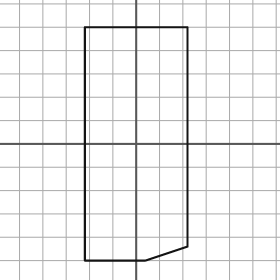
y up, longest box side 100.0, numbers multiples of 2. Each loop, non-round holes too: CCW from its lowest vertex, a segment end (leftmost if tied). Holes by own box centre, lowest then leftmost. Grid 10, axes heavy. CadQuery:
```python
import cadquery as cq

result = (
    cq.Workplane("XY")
    .moveTo(-22.0, -50.0)
    .lineTo(4.0, -50.0)
    .lineTo(22.0, -44.0)
    .lineTo(22.0, 50.0)
    .lineTo(-22.0, 50.0)
    .close()
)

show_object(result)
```